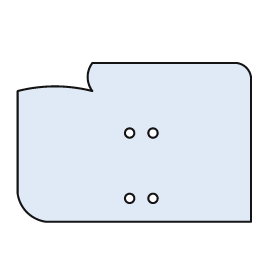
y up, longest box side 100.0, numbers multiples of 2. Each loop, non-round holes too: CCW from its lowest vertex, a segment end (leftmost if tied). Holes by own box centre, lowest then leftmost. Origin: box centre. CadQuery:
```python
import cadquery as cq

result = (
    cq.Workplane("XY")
    .moveTo(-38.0, -34.0)
    .lineTo(50.0, -34.0)
    .lineTo(50.0, 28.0)
    .threePointArc((48.0, 32.0), (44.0, 34.0))
    .lineTo(-18.0, 34.0)
    .threePointArc((-20.0, 28.0), (-18.0, 22.0))
    .threePointArc((-34.0, 24.0), (-50.0, 22.0))
    .lineTo(-50.0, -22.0)
    .threePointArc((-46.0, -30.0), (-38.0, -34.0))
    .close()
    .moveTo(-2.0, -24.0)
    .circle(2.0)
    .moveTo(8.0, -24.0)
    .circle(2.0)
    .moveTo(-2.0, 4.0)
    .circle(2.0)
    .moveTo(8.0, 4.0)
    .circle(2.0)
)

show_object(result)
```